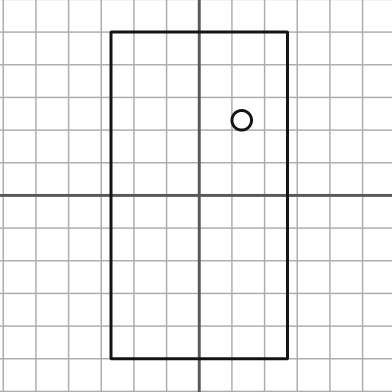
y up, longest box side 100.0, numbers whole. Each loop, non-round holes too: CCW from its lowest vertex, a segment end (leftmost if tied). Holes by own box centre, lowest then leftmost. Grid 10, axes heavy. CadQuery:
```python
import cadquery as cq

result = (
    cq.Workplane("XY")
    .moveTo(-27.0, -50.0)
    .lineTo(27.0, -50.0)
    .lineTo(27.0, 50.0)
    .lineTo(-27.0, 50.0)
    .close()
    .moveTo(13.0, 23.0)
    .circle(3.0)
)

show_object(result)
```